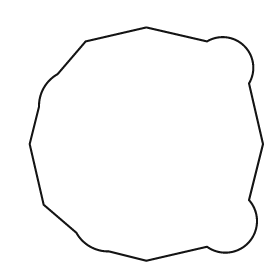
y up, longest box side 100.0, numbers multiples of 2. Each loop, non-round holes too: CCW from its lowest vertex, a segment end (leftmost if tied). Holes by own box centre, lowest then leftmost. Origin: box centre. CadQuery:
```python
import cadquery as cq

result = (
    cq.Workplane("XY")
    .moveTo(0.0, -50.0)
    .lineTo(26.0, -44.0)
    .threePointArc((44.0, -42.0), (44.0, -24.0))
    .lineTo(50.0, 0.0)
    .lineTo(44.0, 26.0)
    .threePointArc((42.0, 42.0), (26.0, 44.0))
    .lineTo(0.0, 50.0)
    .lineTo(-26.0, 44.0)
    .lineTo(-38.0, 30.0)
    .threePointArc((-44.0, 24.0), (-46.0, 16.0))
    .lineTo(-50.0, 0.0)
    .lineTo(-44.0, -26.0)
    .lineTo(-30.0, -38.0)
    .threePointArc((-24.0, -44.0), (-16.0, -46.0))
    .close()
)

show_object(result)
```